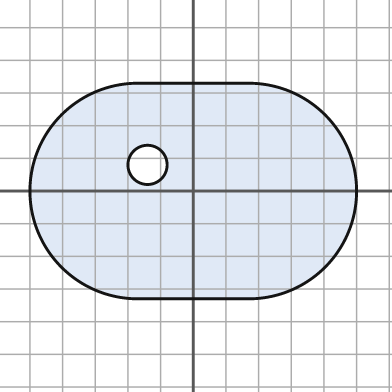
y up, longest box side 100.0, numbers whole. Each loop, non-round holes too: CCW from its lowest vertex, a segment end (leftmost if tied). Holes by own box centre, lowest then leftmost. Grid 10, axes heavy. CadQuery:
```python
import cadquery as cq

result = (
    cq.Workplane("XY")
    .moveTo(-17.0, -33.0)
    .lineTo(17.0, -33.0)
    .threePointArc((50.0, 0.0), (17.0, 33.0))
    .lineTo(-17.0, 33.0)
    .threePointArc((-50.0, 0.0), (-17.0, -33.0))
    .close()
    .moveTo(-14.0, 8.0)
    .circle(6.0)
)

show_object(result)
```